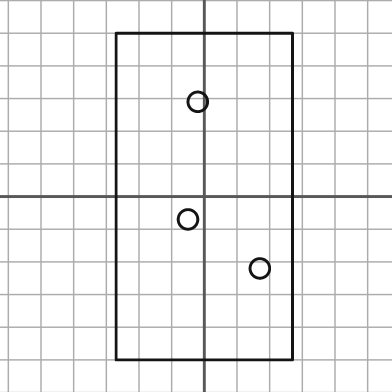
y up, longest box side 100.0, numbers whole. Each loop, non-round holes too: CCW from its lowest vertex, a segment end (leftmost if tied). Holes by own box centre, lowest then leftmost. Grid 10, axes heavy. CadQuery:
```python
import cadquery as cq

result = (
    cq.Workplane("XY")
    .moveTo(-27.0, -50.0)
    .lineTo(27.0, -50.0)
    .lineTo(27.0, 50.0)
    .lineTo(-27.0, 50.0)
    .close()
    .moveTo(17.0, -22.0)
    .circle(3.0)
    .moveTo(-5.0, -7.0)
    .circle(3.0)
    .moveTo(-2.0, 29.0)
    .circle(3.0)
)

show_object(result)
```